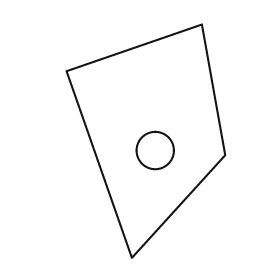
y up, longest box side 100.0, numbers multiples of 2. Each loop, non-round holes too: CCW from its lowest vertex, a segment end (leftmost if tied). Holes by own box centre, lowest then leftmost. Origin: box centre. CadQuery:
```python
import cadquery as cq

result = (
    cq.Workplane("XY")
    .moveTo(-6.0, -50.0)
    .lineTo(34.0, -6.0)
    .lineTo(24.0, 50.0)
    .lineTo(-34.0, 30.0)
    .close()
    .moveTo(4.0, -4.0)
    .circle(8.0)
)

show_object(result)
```